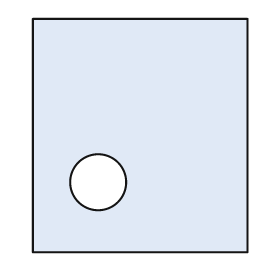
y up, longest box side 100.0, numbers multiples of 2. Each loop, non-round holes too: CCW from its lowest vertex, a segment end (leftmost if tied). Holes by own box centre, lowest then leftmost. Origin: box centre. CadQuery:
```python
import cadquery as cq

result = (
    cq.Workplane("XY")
    .moveTo(-46.0, -50.0)
    .lineTo(46.0, -50.0)
    .lineTo(46.0, 50.0)
    .lineTo(-46.0, 50.0)
    .close()
    .moveTo(-18.0, -20.0)
    .circle(12.0)
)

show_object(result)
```